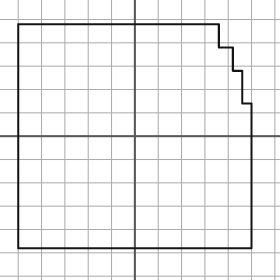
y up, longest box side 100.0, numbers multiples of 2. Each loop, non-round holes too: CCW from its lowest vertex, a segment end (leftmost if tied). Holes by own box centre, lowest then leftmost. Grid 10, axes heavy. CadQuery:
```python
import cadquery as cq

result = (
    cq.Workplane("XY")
    .moveTo(-50.0, -48.0)
    .lineTo(50.0, -48.0)
    .lineTo(50.0, 14.0)
    .lineTo(46.0, 14.0)
    .lineTo(46.0, 28.0)
    .lineTo(42.0, 28.0)
    .lineTo(42.0, 38.0)
    .lineTo(36.0, 38.0)
    .lineTo(36.0, 48.0)
    .lineTo(-50.0, 48.0)
    .close()
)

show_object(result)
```